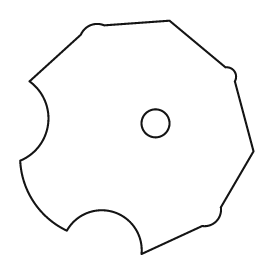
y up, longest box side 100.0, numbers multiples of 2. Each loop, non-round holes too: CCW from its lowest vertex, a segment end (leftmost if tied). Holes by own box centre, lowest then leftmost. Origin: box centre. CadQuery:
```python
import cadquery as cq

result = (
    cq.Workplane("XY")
    .moveTo(2.0, -50.0)
    .lineTo(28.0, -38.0)
    .threePointArc((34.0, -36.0), (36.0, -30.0))
    .lineTo(50.0, -6.0)
    .lineTo(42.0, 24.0)
    .threePointArc((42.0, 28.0), (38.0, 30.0))
    .lineTo(14.0, 50.0)
    .lineTo(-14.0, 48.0)
    .threePointArc((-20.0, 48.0), (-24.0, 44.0))
    .lineTo(-46.0, 24.0)
    .threePointArc((-38.0, 6.0), (-50.0, -10.0))
    .threePointArc((-44.0, -28.0), (-30.0, -40.0))
    .threePointArc((-10.0, -32.0), (2.0, -50.0))
    .close()
    .moveTo(8.0, 6.0)
    .circle(6.0)
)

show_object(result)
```